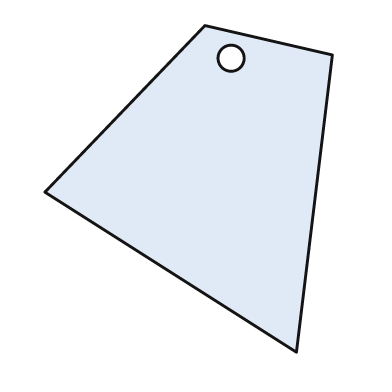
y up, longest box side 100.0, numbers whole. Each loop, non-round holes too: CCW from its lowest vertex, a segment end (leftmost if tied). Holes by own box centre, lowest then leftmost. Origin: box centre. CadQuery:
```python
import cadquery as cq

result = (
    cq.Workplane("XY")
    .moveTo(33.0, -50.0)
    .lineTo(44.0, 41.0)
    .lineTo(5.0, 50.0)
    .lineTo(-44.0, -1.0)
    .close()
    .moveTo(13.0, 40.0)
    .circle(4.0)
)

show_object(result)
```